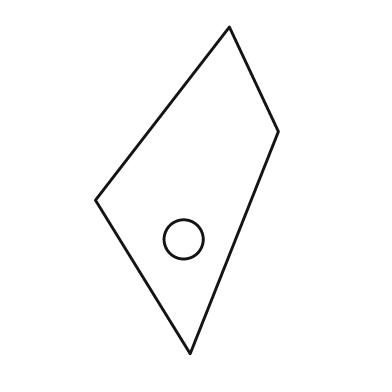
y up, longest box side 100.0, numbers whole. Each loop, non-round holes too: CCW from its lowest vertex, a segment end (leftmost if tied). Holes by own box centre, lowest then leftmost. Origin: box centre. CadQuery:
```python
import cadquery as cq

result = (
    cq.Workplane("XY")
    .moveTo(1.0, -50.0)
    .lineTo(28.0, 18.0)
    .lineTo(13.0, 50.0)
    .lineTo(-28.0, -3.0)
    .close()
    .moveTo(-1.0, -15.0)
    .circle(6.0)
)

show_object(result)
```